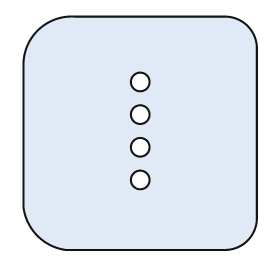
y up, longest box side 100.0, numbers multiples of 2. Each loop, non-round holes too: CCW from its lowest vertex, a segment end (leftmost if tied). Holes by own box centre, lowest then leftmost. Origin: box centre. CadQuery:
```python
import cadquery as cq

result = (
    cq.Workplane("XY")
    .moveTo(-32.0, -50.0)
    .lineTo(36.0, -50.0)
    .threePointArc((46.0, -46.0), (50.0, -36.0))
    .lineTo(50.0, 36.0)
    .threePointArc((46.0, 46.0), (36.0, 50.0))
    .lineTo(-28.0, 50.0)
    .threePointArc((-44.0, 44.0), (-50.0, 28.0))
    .lineTo(-50.0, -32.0)
    .threePointArc((-44.0, -44.0), (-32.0, -50.0))
    .close()
    .moveTo(0.0, -20.0)
    .circle(4.0)
    .moveTo(0.0, -6.0)
    .circle(4.0)
    .moveTo(0.0, 8.0)
    .circle(4.0)
    .moveTo(0.0, 22.0)
    .circle(4.0)
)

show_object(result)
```